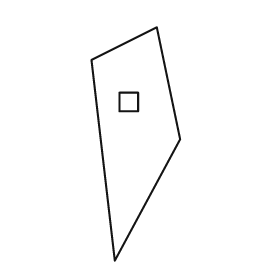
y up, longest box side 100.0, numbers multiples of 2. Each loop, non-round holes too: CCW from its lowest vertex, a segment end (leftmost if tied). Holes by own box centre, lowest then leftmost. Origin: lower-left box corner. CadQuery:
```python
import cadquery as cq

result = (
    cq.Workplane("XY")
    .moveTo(10.0, 0.0)
    .lineTo(38.0, 52.0)
    .lineTo(28.0, 100.0)
    .lineTo(0.0, 86.0)
    .close()
    .moveTo(12.0, 64.0)
    .lineTo(20.0, 64.0)
    .lineTo(20.0, 72.0)
    .lineTo(12.0, 72.0)
    .close()
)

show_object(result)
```